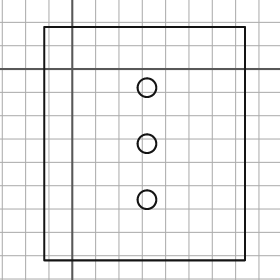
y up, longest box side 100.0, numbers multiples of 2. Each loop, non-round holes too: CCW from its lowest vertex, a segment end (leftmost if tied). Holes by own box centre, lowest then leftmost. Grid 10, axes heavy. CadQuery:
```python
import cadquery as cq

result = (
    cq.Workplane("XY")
    .moveTo(-12.0, -82.0)
    .lineTo(74.0, -82.0)
    .lineTo(74.0, 18.0)
    .lineTo(-12.0, 18.0)
    .close()
    .moveTo(32.0, -56.0)
    .circle(4.0)
    .moveTo(32.0, -32.0)
    .circle(4.0)
    .moveTo(32.0, -8.0)
    .circle(4.0)
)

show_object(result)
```